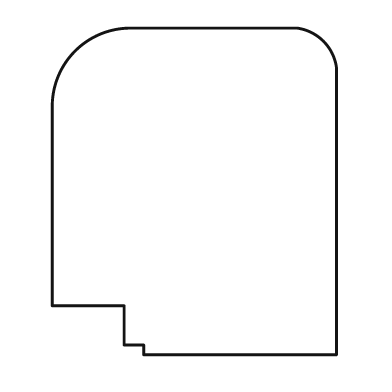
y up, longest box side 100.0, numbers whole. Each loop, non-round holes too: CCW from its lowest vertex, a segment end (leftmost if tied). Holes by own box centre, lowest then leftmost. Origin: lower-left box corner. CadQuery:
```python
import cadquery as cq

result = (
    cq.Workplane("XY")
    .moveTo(28.0, 0.0)
    .lineTo(87.0, 0.0)
    .lineTo(87.0, 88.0)
    .threePointArc((83.0, 96.0), (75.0, 100.0))
    .lineTo(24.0, 100.0)
    .threePointArc((7.0, 93.0), (0.0, 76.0))
    .lineTo(0.0, 15.0)
    .lineTo(22.0, 15.0)
    .lineTo(22.0, 3.0)
    .lineTo(28.0, 3.0)
    .close()
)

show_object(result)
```